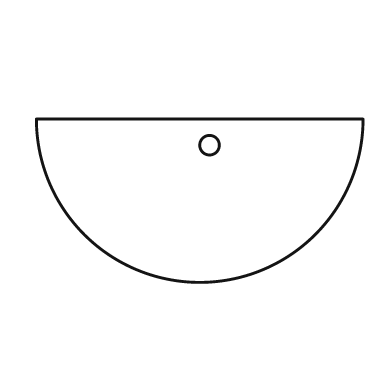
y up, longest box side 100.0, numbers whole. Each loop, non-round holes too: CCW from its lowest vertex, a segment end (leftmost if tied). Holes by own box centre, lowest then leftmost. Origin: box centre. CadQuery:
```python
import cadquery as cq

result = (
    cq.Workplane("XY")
    .moveTo(-50.0, 25.0)
    .threePointArc((0.0, -25.0), (50.0, 25.0))
    .close()
    .moveTo(3.0, 17.0)
    .circle(3.0)
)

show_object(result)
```